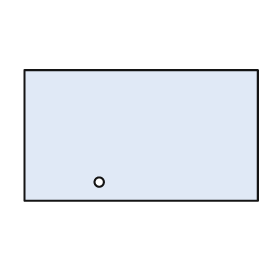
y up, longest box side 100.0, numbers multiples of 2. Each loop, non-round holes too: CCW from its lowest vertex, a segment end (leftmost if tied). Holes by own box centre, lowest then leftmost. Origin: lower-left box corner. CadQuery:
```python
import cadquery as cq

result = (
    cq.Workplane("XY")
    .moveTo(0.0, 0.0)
    .lineTo(100.0, 0.0)
    .lineTo(100.0, 56.0)
    .lineTo(0.0, 56.0)
    .close()
    .moveTo(32.0, 8.0)
    .circle(2.0)
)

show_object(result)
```